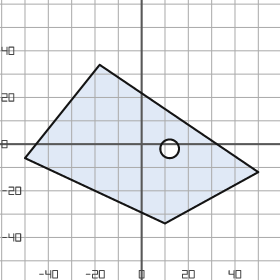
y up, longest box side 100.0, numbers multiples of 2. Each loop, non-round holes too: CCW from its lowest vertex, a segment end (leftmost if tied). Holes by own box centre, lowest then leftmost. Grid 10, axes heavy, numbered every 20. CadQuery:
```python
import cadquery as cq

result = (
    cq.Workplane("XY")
    .moveTo(10.0, -34.0)
    .lineTo(50.0, -12.0)
    .lineTo(-18.0, 34.0)
    .lineTo(-50.0, -6.0)
    .close()
    .moveTo(12.0, -2.0)
    .circle(4.0)
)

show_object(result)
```